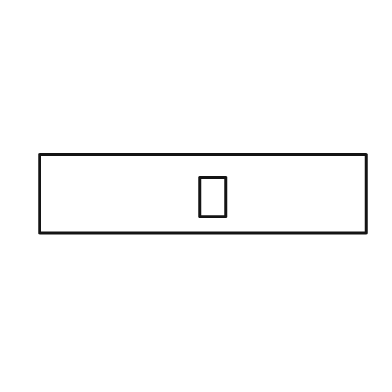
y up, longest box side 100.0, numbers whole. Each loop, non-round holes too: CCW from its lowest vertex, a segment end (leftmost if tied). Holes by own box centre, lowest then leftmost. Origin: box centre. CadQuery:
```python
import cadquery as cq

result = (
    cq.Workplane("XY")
    .moveTo(-50.0, -12.0)
    .lineTo(50.0, -12.0)
    .lineTo(50.0, 12.0)
    .lineTo(-50.0, 12.0)
    .close()
    .moveTo(-1.0, -7.0)
    .lineTo(7.0, -7.0)
    .lineTo(7.0, 5.0)
    .lineTo(-1.0, 5.0)
    .close()
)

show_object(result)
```